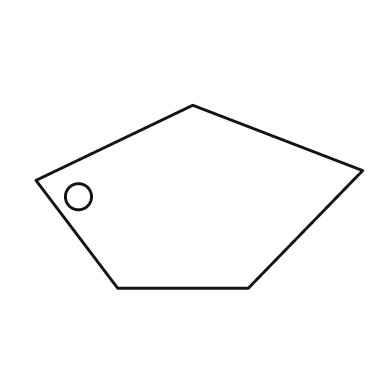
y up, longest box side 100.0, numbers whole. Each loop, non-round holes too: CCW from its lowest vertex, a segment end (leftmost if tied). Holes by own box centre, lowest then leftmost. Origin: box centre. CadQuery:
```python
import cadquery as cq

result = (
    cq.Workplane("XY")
    .moveTo(-25.0, -28.0)
    .lineTo(15.0, -28.0)
    .lineTo(50.0, 8.0)
    .lineTo(-2.0, 28.0)
    .lineTo(-50.0, 5.0)
    .close()
    .moveTo(-37.0, 0.0)
    .circle(4.0)
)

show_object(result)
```